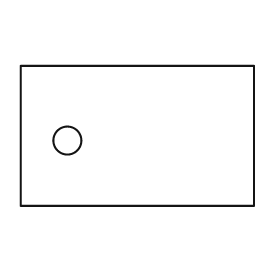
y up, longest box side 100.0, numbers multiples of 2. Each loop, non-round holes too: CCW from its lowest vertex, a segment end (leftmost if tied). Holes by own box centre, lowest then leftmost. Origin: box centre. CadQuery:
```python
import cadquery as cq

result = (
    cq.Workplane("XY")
    .moveTo(-50.0, -30.0)
    .lineTo(50.0, -30.0)
    .lineTo(50.0, 30.0)
    .lineTo(-50.0, 30.0)
    .close()
    .moveTo(-30.0, -2.0)
    .circle(6.0)
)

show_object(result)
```